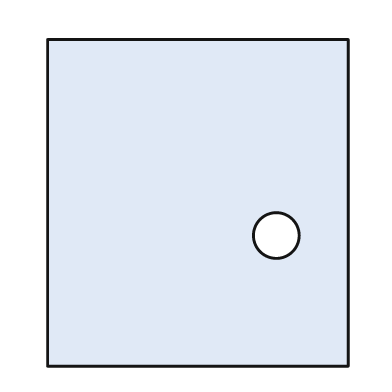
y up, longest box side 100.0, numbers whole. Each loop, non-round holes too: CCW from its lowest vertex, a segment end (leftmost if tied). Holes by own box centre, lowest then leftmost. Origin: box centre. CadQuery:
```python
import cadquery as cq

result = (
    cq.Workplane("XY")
    .moveTo(-46.0, -50.0)
    .lineTo(46.0, -50.0)
    .lineTo(46.0, 50.0)
    .lineTo(-46.0, 50.0)
    .close()
    .moveTo(24.0, -10.0)
    .circle(7.0)
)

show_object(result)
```